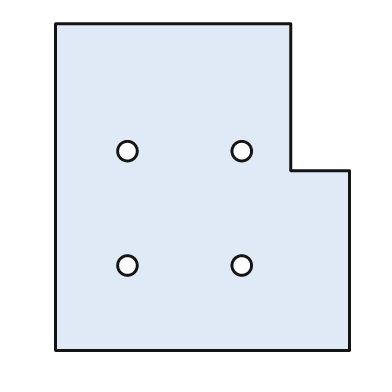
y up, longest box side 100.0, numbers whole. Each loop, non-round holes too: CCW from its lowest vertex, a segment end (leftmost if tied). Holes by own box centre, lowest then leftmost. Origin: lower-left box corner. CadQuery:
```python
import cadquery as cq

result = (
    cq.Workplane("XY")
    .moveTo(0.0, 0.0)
    .lineTo(90.0, 0.0)
    .lineTo(90.0, 55.0)
    .lineTo(72.0, 55.0)
    .lineTo(72.0, 100.0)
    .lineTo(0.0, 100.0)
    .close()
    .moveTo(22.0, 26.0)
    .circle(3.0)
    .moveTo(57.0, 26.0)
    .circle(3.0)
    .moveTo(22.0, 61.0)
    .circle(3.0)
    .moveTo(57.0, 61.0)
    .circle(3.0)
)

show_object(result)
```